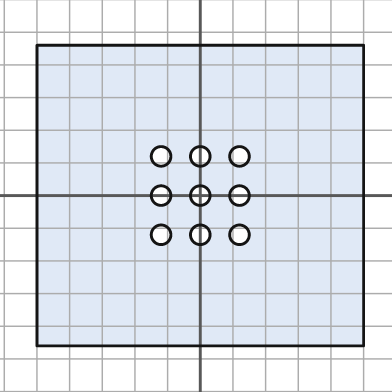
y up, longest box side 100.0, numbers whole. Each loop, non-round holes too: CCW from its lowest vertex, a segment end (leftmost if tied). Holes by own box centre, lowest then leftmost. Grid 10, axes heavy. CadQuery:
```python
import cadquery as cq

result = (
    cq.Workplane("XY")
    .moveTo(-50.0, -46.0)
    .lineTo(50.0, -46.0)
    .lineTo(50.0, 46.0)
    .lineTo(-50.0, 46.0)
    .close()
    .moveTo(-12.0, -12.0)
    .circle(3.0)
    .moveTo(0.0, -12.0)
    .circle(3.0)
    .moveTo(12.0, -12.0)
    .circle(3.0)
    .moveTo(-12.0, 0.0)
    .circle(3.0)
    .moveTo(0.0, 0.0)
    .circle(3.0)
    .moveTo(12.0, 0.0)
    .circle(3.0)
    .moveTo(-12.0, 12.0)
    .circle(3.0)
    .moveTo(0.0, 12.0)
    .circle(3.0)
    .moveTo(12.0, 12.0)
    .circle(3.0)
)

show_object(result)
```